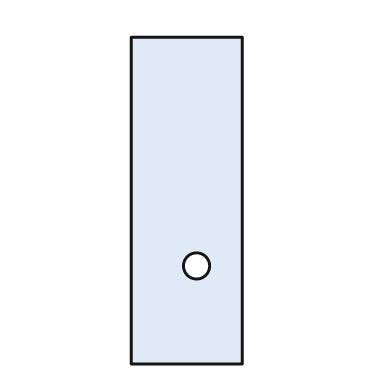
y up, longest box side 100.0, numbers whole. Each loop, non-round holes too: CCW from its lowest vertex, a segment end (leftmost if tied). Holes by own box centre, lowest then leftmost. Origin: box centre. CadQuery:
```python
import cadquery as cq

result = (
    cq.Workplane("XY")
    .moveTo(-17.0, -50.0)
    .lineTo(17.0, -50.0)
    .lineTo(17.0, 50.0)
    .lineTo(-17.0, 50.0)
    .close()
    .moveTo(3.0, -20.0)
    .circle(4.0)
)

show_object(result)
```